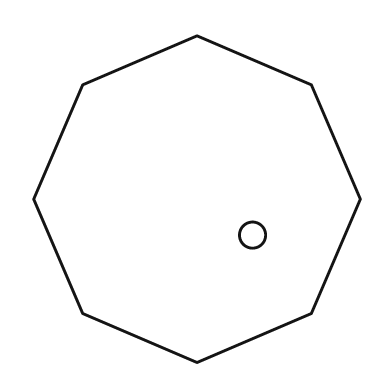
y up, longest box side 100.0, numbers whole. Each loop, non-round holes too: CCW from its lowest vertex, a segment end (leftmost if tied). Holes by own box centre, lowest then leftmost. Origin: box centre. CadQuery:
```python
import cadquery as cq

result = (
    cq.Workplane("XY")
    .moveTo(0.0, -50.0)
    .lineTo(35.0, -35.0)
    .lineTo(50.0, 0.0)
    .lineTo(35.0, 35.0)
    .lineTo(0.0, 50.0)
    .lineTo(-35.0, 35.0)
    .lineTo(-50.0, 0.0)
    .lineTo(-35.0, -35.0)
    .close()
    .moveTo(17.0, -11.0)
    .circle(4.0)
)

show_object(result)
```